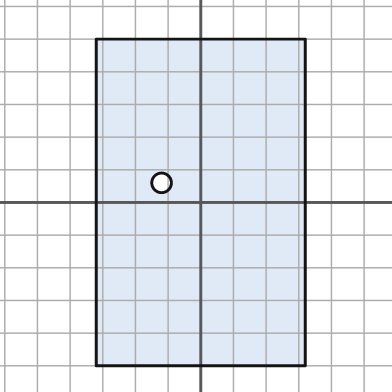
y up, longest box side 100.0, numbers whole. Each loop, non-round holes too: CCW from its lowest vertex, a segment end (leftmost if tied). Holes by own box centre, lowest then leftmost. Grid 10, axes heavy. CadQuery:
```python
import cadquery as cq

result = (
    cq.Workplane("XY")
    .moveTo(-32.0, -50.0)
    .lineTo(32.0, -50.0)
    .lineTo(32.0, 50.0)
    .lineTo(-32.0, 50.0)
    .close()
    .moveTo(-12.0, 6.0)
    .circle(3.0)
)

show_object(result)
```